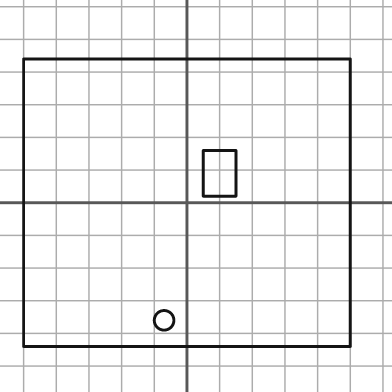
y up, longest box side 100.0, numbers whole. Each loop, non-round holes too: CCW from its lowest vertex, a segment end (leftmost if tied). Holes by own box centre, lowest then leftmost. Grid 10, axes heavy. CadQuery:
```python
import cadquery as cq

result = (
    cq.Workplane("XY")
    .moveTo(-50.0, -44.0)
    .lineTo(50.0, -44.0)
    .lineTo(50.0, 44.0)
    .lineTo(-50.0, 44.0)
    .close()
    .moveTo(-7.0, -36.0)
    .circle(3.0)
    .moveTo(5.0, 2.0)
    .lineTo(15.0, 2.0)
    .lineTo(15.0, 16.0)
    .lineTo(5.0, 16.0)
    .close()
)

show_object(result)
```